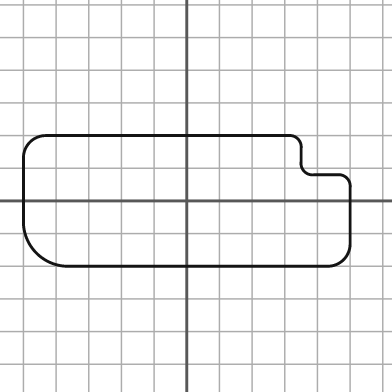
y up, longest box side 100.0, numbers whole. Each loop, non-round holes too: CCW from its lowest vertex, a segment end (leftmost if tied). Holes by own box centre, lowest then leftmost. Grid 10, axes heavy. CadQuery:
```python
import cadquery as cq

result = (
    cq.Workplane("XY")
    .moveTo(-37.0, -20.0)
    .lineTo(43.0, -20.0)
    .threePointArc((48.0, -18.0), (50.0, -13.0))
    .lineTo(50.0, 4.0)
    .threePointArc((49.0, 7.0), (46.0, 8.0))
    .lineTo(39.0, 8.0)
    .threePointArc((36.0, 9.0), (35.0, 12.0))
    .lineTo(35.0, 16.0)
    .threePointArc((34.0, 19.0), (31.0, 20.0))
    .lineTo(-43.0, 20.0)
    .threePointArc((-48.0, 18.0), (-50.0, 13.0))
    .lineTo(-50.0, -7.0)
    .threePointArc((-46.0, -16.0), (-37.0, -20.0))
    .close()
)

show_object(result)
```